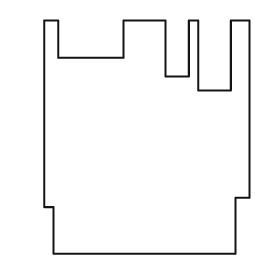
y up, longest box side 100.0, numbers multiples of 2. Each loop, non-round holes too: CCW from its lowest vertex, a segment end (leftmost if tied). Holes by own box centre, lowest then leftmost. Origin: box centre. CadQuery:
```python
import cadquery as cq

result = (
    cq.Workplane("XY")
    .moveTo(-40.0, -50.0)
    .lineTo(38.0, -50.0)
    .lineTo(38.0, -26.0)
    .lineTo(44.0, -26.0)
    .lineTo(44.0, 50.0)
    .lineTo(36.0, 50.0)
    .lineTo(36.0, 20.0)
    .lineTo(22.0, 20.0)
    .lineTo(22.0, 50.0)
    .lineTo(18.0, 50.0)
    .lineTo(18.0, 26.0)
    .lineTo(8.0, 26.0)
    .lineTo(8.0, 50.0)
    .lineTo(-10.0, 50.0)
    .lineTo(-10.0, 34.0)
    .lineTo(-38.0, 34.0)
    .lineTo(-38.0, 50.0)
    .lineTo(-44.0, 50.0)
    .lineTo(-44.0, -30.0)
    .lineTo(-40.0, -30.0)
    .close()
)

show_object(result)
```